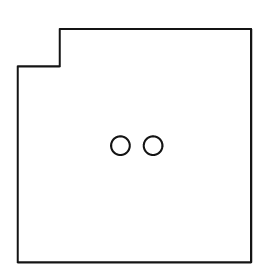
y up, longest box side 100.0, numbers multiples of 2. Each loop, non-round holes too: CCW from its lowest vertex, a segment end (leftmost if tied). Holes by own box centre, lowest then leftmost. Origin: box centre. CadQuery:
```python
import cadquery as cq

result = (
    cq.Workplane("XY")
    .moveTo(-50.0, -50.0)
    .lineTo(50.0, -50.0)
    .lineTo(50.0, 50.0)
    .lineTo(-32.0, 50.0)
    .lineTo(-32.0, 34.0)
    .lineTo(-50.0, 34.0)
    .close()
    .moveTo(-6.0, 0.0)
    .circle(4.0)
    .moveTo(8.0, 0.0)
    .circle(4.0)
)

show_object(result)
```